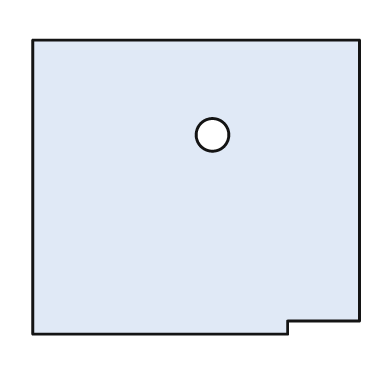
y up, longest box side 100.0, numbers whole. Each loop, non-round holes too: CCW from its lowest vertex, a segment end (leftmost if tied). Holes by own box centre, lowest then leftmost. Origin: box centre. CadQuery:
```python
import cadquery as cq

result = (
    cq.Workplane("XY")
    .moveTo(-50.0, -45.0)
    .lineTo(28.0, -45.0)
    .lineTo(28.0, -41.0)
    .lineTo(50.0, -41.0)
    .lineTo(50.0, 45.0)
    .lineTo(-50.0, 45.0)
    .close()
    .moveTo(5.0, 16.0)
    .circle(5.0)
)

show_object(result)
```